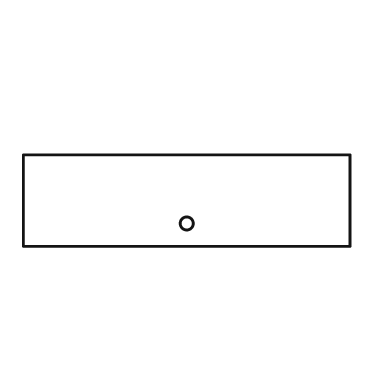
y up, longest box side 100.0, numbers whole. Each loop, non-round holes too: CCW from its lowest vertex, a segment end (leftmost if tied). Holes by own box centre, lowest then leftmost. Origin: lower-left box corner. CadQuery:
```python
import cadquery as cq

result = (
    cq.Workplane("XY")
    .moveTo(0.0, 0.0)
    .lineTo(100.0, 0.0)
    .lineTo(100.0, 28.0)
    .lineTo(0.0, 28.0)
    .close()
    .moveTo(50.0, 7.0)
    .circle(2.0)
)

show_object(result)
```